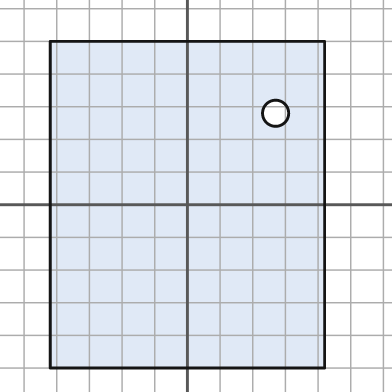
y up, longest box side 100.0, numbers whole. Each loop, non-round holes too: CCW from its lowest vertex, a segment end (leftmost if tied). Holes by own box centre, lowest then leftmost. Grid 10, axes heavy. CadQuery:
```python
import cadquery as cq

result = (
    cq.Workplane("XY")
    .moveTo(-42.0, -50.0)
    .lineTo(42.0, -50.0)
    .lineTo(42.0, 50.0)
    .lineTo(-42.0, 50.0)
    .close()
    .moveTo(27.0, 28.0)
    .circle(4.0)
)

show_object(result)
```